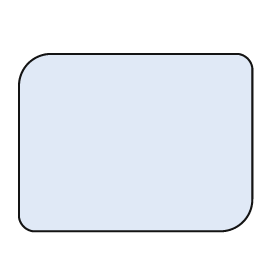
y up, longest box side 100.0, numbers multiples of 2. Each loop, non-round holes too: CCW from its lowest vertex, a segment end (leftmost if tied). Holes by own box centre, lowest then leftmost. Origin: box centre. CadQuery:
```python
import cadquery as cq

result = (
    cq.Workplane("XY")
    .moveTo(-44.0, -38.0)
    .lineTo(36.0, -38.0)
    .threePointArc((46.0, -34.0), (50.0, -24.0))
    .lineTo(50.0, 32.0)
    .threePointArc((48.0, 36.0), (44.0, 38.0))
    .lineTo(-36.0, 38.0)
    .threePointArc((-46.0, 34.0), (-50.0, 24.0))
    .lineTo(-50.0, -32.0)
    .threePointArc((-48.0, -36.0), (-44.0, -38.0))
    .close()
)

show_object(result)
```